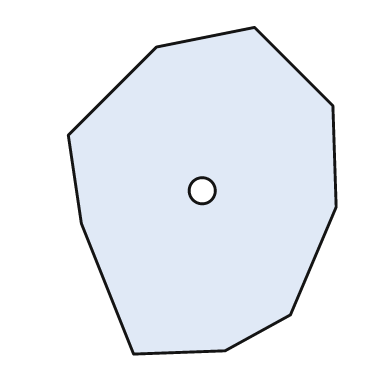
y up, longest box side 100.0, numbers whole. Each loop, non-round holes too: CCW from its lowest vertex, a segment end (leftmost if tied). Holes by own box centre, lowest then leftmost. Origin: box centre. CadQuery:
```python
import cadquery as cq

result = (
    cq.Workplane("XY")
    .moveTo(-21.0, -50.0)
    .lineTo(7.0, -49.0)
    .lineTo(27.0, -38.0)
    .lineTo(41.0, -5.0)
    .lineTo(40.0, 26.0)
    .lineTo(16.0, 50.0)
    .lineTo(-14.0, 44.0)
    .lineTo(-41.0, 17.0)
    .lineTo(-37.0, -10.0)
    .close()
    .moveTo(0.0, 0.0)
    .circle(4.0)
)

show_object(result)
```